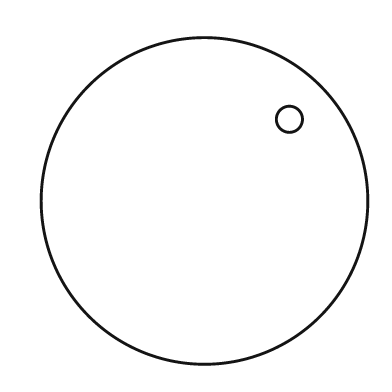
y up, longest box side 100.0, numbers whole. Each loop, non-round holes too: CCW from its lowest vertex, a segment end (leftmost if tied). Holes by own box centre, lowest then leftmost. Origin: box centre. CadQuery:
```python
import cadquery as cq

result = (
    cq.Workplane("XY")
    .moveTo(0.0, 0.0)
    .circle(50.0)
    .moveTo(26.0, 25.0)
    .circle(4.0)
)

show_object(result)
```